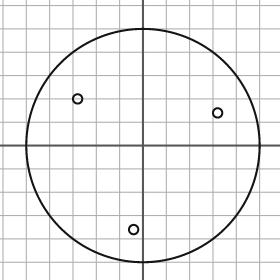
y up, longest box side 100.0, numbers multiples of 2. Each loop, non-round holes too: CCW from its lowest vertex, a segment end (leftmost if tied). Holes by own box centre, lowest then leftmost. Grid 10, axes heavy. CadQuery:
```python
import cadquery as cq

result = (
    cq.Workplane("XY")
    .moveTo(0.0, 0.0)
    .circle(50.0)
    .moveTo(-4.0, -36.0)
    .circle(2.0)
    .moveTo(32.0, 14.0)
    .circle(2.0)
    .moveTo(-28.0, 20.0)
    .circle(2.0)
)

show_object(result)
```